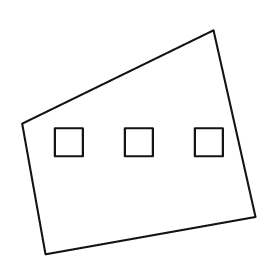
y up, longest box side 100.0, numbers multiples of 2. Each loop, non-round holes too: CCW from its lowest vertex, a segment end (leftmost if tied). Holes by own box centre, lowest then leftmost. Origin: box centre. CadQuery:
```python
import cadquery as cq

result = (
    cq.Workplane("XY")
    .moveTo(-40.0, -48.0)
    .lineTo(50.0, -32.0)
    .lineTo(32.0, 48.0)
    .lineTo(-50.0, 8.0)
    .close()
    .moveTo(-36.0, -6.0)
    .lineTo(-24.0, -6.0)
    .lineTo(-24.0, 6.0)
    .lineTo(-36.0, 6.0)
    .close()
    .moveTo(-6.0, -6.0)
    .lineTo(6.0, -6.0)
    .lineTo(6.0, 6.0)
    .lineTo(-6.0, 6.0)
    .close()
    .moveTo(24.0, -6.0)
    .lineTo(36.0, -6.0)
    .lineTo(36.0, 6.0)
    .lineTo(24.0, 6.0)
    .close()
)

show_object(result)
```